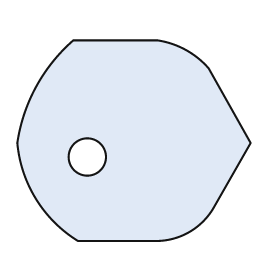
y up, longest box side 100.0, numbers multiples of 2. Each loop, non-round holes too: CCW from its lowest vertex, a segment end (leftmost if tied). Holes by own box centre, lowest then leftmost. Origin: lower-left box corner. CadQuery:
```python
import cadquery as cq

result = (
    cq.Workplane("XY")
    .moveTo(26.0, 0.0)
    .lineTo(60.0, 0.0)
    .threePointArc((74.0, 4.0), (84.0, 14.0))
    .lineTo(100.0, 42.0)
    .lineTo(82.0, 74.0)
    .threePointArc((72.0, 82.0), (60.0, 86.0))
    .lineTo(24.0, 86.0)
    .threePointArc((8.0, 66.0), (0.0, 42.0))
    .threePointArc((8.0, 18.0), (26.0, 0.0))
    .close()
    .moveTo(30.0, 36.0)
    .circle(8.0)
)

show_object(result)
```